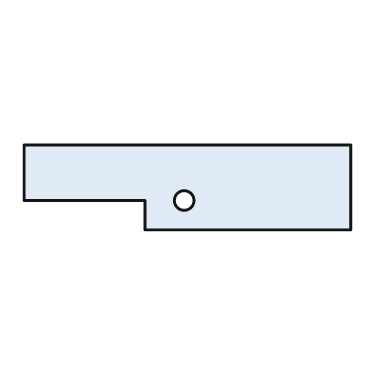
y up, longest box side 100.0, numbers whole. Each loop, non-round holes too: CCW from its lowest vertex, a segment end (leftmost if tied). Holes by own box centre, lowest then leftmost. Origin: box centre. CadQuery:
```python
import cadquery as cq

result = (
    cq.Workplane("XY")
    .moveTo(-13.0, -13.0)
    .lineTo(50.0, -13.0)
    .lineTo(50.0, 13.0)
    .lineTo(-50.0, 13.0)
    .lineTo(-50.0, -4.0)
    .lineTo(-13.0, -4.0)
    .close()
    .moveTo(-1.0, -4.0)
    .circle(3.0)
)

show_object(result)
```